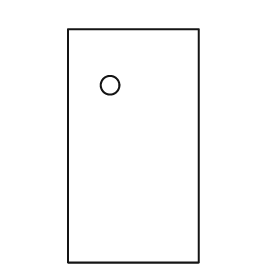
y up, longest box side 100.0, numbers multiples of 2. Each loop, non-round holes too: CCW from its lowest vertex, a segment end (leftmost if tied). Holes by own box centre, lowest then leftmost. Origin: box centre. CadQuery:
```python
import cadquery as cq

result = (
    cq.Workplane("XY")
    .moveTo(-28.0, -50.0)
    .lineTo(28.0, -50.0)
    .lineTo(28.0, 50.0)
    .lineTo(-28.0, 50.0)
    .close()
    .moveTo(-10.0, 26.0)
    .circle(4.0)
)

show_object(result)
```